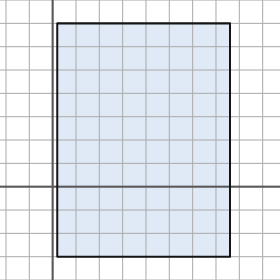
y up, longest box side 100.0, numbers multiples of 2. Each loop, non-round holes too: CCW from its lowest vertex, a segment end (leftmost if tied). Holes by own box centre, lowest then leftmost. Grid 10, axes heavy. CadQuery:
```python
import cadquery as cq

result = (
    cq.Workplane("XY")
    .moveTo(2.0, -30.0)
    .lineTo(76.0, -30.0)
    .lineTo(76.0, 70.0)
    .lineTo(2.0, 70.0)
    .close()
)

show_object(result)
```